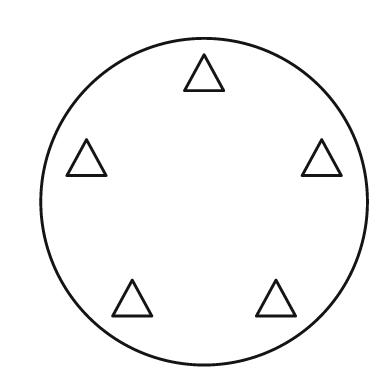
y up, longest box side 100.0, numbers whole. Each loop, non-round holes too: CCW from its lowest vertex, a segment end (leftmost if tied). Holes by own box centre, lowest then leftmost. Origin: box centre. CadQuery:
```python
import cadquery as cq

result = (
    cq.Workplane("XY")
    .moveTo(0.0, 0.0)
    .circle(50.0)
    .moveTo(-28.0, -35.0)
    .lineTo(-16.0, -35.0)
    .lineTo(-22.0, -24.0)
    .close()
    .moveTo(16.0, -35.0)
    .lineTo(28.0, -35.0)
    .lineTo(22.0, -24.0)
    .close()
    .moveTo(-42.0, 8.0)
    .lineTo(-30.0, 8.0)
    .lineTo(-36.0, 19.0)
    .close()
    .moveTo(30.0, 8.0)
    .lineTo(42.0, 8.0)
    .lineTo(36.0, 19.0)
    .close()
    .moveTo(-6.0, 34.0)
    .lineTo(6.0, 34.0)
    .lineTo(0.0, 45.0)
    .close()
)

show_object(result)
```